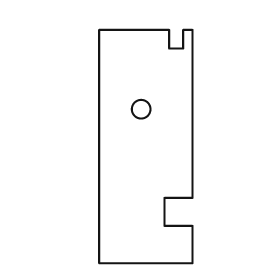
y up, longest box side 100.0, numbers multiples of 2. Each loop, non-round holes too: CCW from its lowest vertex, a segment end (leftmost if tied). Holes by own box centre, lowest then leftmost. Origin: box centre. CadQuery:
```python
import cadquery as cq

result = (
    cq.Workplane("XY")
    .moveTo(-20.0, -50.0)
    .lineTo(20.0, -50.0)
    .lineTo(20.0, -34.0)
    .lineTo(8.0, -34.0)
    .lineTo(8.0, -22.0)
    .lineTo(20.0, -22.0)
    .lineTo(20.0, 50.0)
    .lineTo(16.0, 50.0)
    .lineTo(16.0, 42.0)
    .lineTo(10.0, 42.0)
    .lineTo(10.0, 50.0)
    .lineTo(-20.0, 50.0)
    .close()
    .moveTo(-2.0, 16.0)
    .circle(4.0)
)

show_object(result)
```